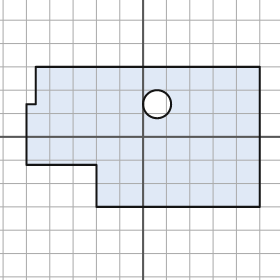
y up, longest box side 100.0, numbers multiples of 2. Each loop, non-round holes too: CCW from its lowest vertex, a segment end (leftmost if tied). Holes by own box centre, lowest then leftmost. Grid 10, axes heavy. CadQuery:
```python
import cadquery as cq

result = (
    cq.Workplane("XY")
    .moveTo(-20.0, -30.0)
    .lineTo(50.0, -30.0)
    .lineTo(50.0, 30.0)
    .lineTo(-46.0, 30.0)
    .lineTo(-46.0, 14.0)
    .lineTo(-50.0, 14.0)
    .lineTo(-50.0, -12.0)
    .lineTo(-20.0, -12.0)
    .close()
    .moveTo(6.0, 14.0)
    .circle(6.0)
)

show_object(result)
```